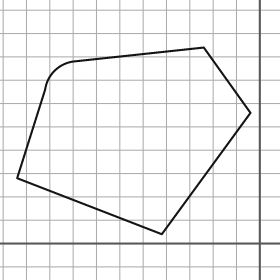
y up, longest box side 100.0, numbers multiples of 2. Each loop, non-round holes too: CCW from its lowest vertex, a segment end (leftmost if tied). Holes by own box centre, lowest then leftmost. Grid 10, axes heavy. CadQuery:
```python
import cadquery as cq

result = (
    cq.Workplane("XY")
    .moveTo(-42.0, 4.0)
    .lineTo(-4.0, 56.0)
    .lineTo(-24.0, 84.0)
    .lineTo(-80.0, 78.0)
    .threePointArc((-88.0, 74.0), (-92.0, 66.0))
    .lineTo(-104.0, 28.0)
    .close()
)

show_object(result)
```